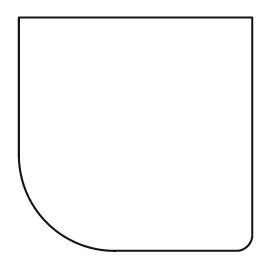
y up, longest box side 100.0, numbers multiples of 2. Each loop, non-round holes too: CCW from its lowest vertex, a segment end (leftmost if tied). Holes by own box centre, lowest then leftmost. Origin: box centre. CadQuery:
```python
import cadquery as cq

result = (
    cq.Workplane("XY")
    .moveTo(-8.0, -50.0)
    .lineTo(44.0, -50.0)
    .threePointArc((48.0, -48.0), (50.0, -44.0))
    .lineTo(50.0, 50.0)
    .lineTo(-50.0, 50.0)
    .lineTo(-50.0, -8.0)
    .threePointArc((-38.0, -38.0), (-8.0, -50.0))
    .close()
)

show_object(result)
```